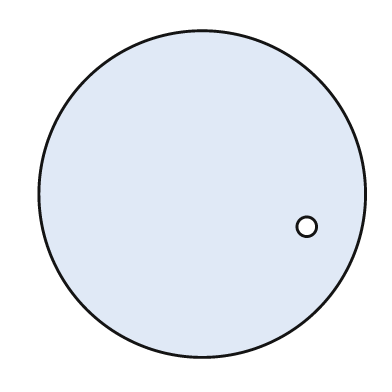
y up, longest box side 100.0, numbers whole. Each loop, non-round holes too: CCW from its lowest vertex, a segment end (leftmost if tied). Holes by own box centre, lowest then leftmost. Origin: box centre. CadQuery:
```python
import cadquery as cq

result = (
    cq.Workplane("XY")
    .moveTo(0.0, 0.0)
    .circle(50.0)
    .moveTo(32.0, -10.0)
    .circle(3.0)
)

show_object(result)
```